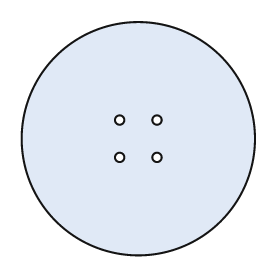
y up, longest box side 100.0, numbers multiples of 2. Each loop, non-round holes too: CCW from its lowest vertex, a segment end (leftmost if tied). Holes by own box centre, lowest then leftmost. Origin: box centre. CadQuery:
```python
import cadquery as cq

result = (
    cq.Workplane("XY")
    .moveTo(0.0, 0.0)
    .circle(50.0)
    .moveTo(-8.0, -8.0)
    .circle(2.0)
    .moveTo(8.0, -8.0)
    .circle(2.0)
    .moveTo(-8.0, 8.0)
    .circle(2.0)
    .moveTo(8.0, 8.0)
    .circle(2.0)
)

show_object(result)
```